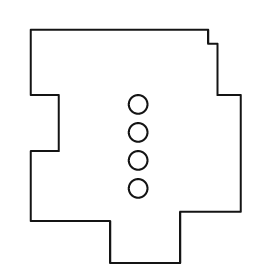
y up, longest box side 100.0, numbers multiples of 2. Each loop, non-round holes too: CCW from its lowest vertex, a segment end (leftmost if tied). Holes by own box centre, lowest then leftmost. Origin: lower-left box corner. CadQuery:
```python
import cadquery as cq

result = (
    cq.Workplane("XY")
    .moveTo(34.0, 0.0)
    .lineTo(64.0, 0.0)
    .lineTo(64.0, 22.0)
    .lineTo(90.0, 22.0)
    .lineTo(90.0, 72.0)
    .lineTo(80.0, 72.0)
    .lineTo(80.0, 94.0)
    .lineTo(76.0, 94.0)
    .lineTo(76.0, 100.0)
    .lineTo(0.0, 100.0)
    .lineTo(0.0, 72.0)
    .lineTo(12.0, 72.0)
    .lineTo(12.0, 48.0)
    .lineTo(0.0, 48.0)
    .lineTo(0.0, 18.0)
    .lineTo(34.0, 18.0)
    .close()
    .moveTo(46.0, 32.0)
    .circle(4.0)
    .moveTo(46.0, 44.0)
    .circle(4.0)
    .moveTo(46.0, 56.0)
    .circle(4.0)
    .moveTo(46.0, 68.0)
    .circle(4.0)
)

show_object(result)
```